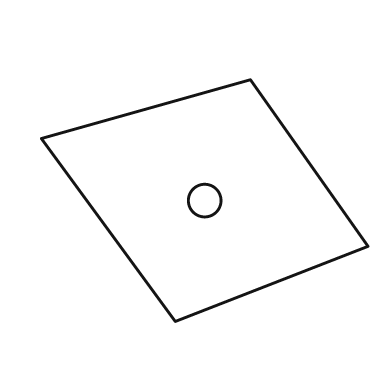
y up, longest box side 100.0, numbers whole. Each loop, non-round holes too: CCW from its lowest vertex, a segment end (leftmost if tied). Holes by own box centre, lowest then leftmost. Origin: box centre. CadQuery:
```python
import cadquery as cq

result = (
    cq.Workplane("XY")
    .moveTo(-9.0, -37.0)
    .lineTo(50.0, -14.0)
    .lineTo(14.0, 37.0)
    .lineTo(-50.0, 19.0)
    .close()
    .moveTo(0.0, 0.0)
    .circle(5.0)
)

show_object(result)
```